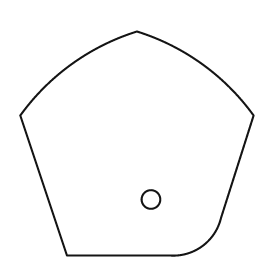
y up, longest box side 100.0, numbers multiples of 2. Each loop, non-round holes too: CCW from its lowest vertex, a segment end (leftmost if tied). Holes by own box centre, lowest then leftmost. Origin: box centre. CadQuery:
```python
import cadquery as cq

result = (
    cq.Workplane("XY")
    .moveTo(-30.0, -48.0)
    .lineTo(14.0, -48.0)
    .threePointArc((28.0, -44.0), (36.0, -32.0))
    .lineTo(50.0, 12.0)
    .threePointArc((28.0, 34.0), (0.0, 48.0))
    .threePointArc((-28.0, 34.0), (-50.0, 12.0))
    .close()
    .moveTo(6.0, -24.0)
    .circle(4.0)
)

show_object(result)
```